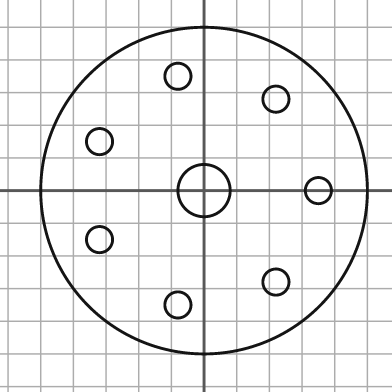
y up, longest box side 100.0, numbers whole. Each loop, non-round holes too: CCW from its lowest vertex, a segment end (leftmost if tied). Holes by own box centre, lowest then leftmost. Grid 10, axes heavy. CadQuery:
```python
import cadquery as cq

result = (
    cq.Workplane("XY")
    .moveTo(0.0, 0.0)
    .circle(50.0)
    .moveTo(-8.0, -35.0)
    .circle(4.0)
    .moveTo(22.0, -28.0)
    .circle(4.0)
    .moveTo(-32.0, -15.0)
    .circle(4.0)
    .moveTo(0.0, 0.0)
    .circle(8.0)
    .moveTo(35.0, 0.0)
    .circle(4.0)
    .moveTo(-32.0, 15.0)
    .circle(4.0)
    .moveTo(22.0, 28.0)
    .circle(4.0)
    .moveTo(-8.0, 35.0)
    .circle(4.0)
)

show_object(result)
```